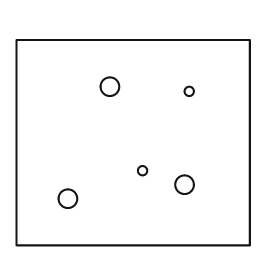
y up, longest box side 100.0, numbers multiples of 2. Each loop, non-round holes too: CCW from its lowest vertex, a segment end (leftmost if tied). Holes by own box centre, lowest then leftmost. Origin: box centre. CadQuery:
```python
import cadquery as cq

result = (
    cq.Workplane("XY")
    .moveTo(-50.0, -44.0)
    .lineTo(50.0, -44.0)
    .lineTo(50.0, 44.0)
    .lineTo(-50.0, 44.0)
    .close()
    .moveTo(-28.0, -24.0)
    .circle(4.0)
    .moveTo(22.0, -18.0)
    .circle(4.0)
    .moveTo(4.0, -12.0)
    .circle(2.0)
    .moveTo(24.0, 22.0)
    .circle(2.0)
    .moveTo(-10.0, 24.0)
    .circle(4.0)
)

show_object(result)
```